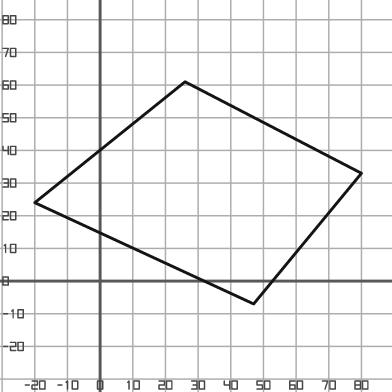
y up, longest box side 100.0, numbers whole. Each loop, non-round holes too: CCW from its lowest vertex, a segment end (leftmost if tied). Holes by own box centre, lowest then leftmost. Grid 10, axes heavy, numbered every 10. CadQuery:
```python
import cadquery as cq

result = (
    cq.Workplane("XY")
    .moveTo(47.0, -7.0)
    .lineTo(80.0, 33.0)
    .lineTo(26.0, 61.0)
    .lineTo(-20.0, 24.0)
    .close()
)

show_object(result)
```